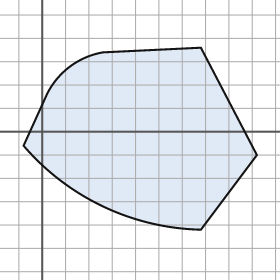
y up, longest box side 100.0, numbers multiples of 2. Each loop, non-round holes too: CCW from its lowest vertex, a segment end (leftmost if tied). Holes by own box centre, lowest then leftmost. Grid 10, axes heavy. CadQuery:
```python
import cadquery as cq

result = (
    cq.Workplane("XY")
    .moveTo(68.0, -42.0)
    .lineTo(92.0, -10.0)
    .lineTo(68.0, 36.0)
    .lineTo(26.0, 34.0)
    .threePointArc((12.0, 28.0), (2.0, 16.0))
    .lineTo(-8.0, -6.0)
    .threePointArc((26.0, -32.0), (68.0, -42.0))
    .close()
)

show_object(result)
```